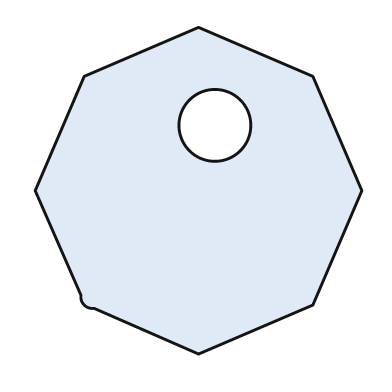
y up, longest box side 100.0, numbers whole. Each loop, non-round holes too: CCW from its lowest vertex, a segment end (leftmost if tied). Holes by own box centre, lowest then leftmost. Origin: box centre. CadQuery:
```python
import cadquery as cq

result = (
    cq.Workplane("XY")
    .moveTo(0.0, -50.0)
    .lineTo(35.0, -35.0)
    .lineTo(50.0, 0.0)
    .lineTo(35.0, 35.0)
    .lineTo(0.0, 50.0)
    .lineTo(-35.0, 35.0)
    .lineTo(-50.0, 0.0)
    .lineTo(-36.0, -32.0)
    .threePointArc((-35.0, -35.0), (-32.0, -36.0))
    .close()
    .moveTo(5.0, 20.0)
    .circle(11.0)
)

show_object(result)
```